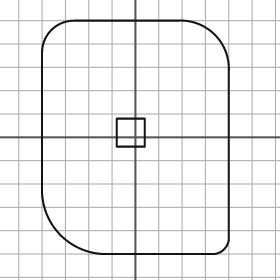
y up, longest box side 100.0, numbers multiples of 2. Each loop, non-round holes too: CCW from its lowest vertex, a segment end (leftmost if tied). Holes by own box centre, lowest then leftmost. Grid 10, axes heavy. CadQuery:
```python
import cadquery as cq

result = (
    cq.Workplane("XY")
    .moveTo(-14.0, -50.0)
    .lineTo(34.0, -50.0)
    .threePointArc((38.0, -48.0), (40.0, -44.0))
    .lineTo(40.0, 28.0)
    .threePointArc((34.0, 44.0), (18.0, 50.0))
    .lineTo(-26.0, 50.0)
    .threePointArc((-36.0, 46.0), (-40.0, 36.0))
    .lineTo(-40.0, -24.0)
    .threePointArc((-32.0, -42.0), (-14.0, -50.0))
    .close()
    .moveTo(-8.0, -4.0)
    .lineTo(4.0, -4.0)
    .lineTo(4.0, 8.0)
    .lineTo(-8.0, 8.0)
    .close()
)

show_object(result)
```